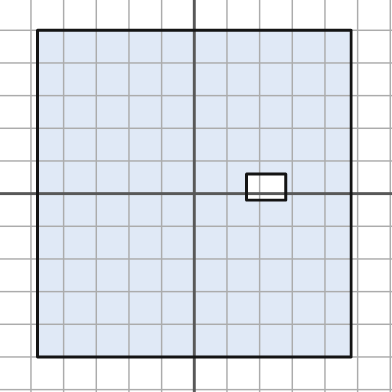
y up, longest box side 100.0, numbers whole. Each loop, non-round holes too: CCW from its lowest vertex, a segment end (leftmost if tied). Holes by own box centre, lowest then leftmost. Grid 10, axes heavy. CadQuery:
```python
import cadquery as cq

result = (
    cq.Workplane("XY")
    .moveTo(-48.0, -50.0)
    .lineTo(48.0, -50.0)
    .lineTo(48.0, 50.0)
    .lineTo(-48.0, 50.0)
    .close()
    .moveTo(16.0, -2.0)
    .lineTo(28.0, -2.0)
    .lineTo(28.0, 6.0)
    .lineTo(16.0, 6.0)
    .close()
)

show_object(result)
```